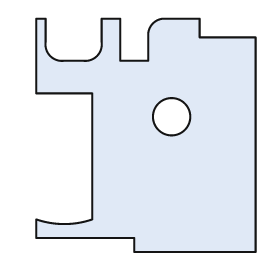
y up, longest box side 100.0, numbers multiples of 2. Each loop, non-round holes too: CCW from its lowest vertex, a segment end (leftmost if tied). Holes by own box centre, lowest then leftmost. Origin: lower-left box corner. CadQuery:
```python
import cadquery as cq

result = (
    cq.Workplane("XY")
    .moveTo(42.0, 0.0)
    .lineTo(94.0, 0.0)
    .lineTo(94.0, 92.0)
    .lineTo(70.0, 92.0)
    .lineTo(70.0, 100.0)
    .lineTo(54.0, 100.0)
    .threePointArc((50.0, 98.0), (48.0, 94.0))
    .lineTo(48.0, 82.0)
    .lineTo(36.0, 82.0)
    .lineTo(36.0, 100.0)
    .lineTo(28.0, 100.0)
    .lineTo(28.0, 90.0)
    .threePointArc((26.0, 84.0), (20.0, 82.0))
    .lineTo(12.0, 82.0)
    .threePointArc((6.0, 84.0), (4.0, 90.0))
    .lineTo(4.0, 100.0)
    .lineTo(0.0, 100.0)
    .lineTo(0.0, 68.0)
    .lineTo(24.0, 68.0)
    .lineTo(24.0, 14.0)
    .threePointArc((12.0, 12.0), (0.0, 14.0))
    .lineTo(0.0, 6.0)
    .lineTo(42.0, 6.0)
    .close()
    .moveTo(58.0, 58.0)
    .circle(8.0)
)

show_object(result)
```